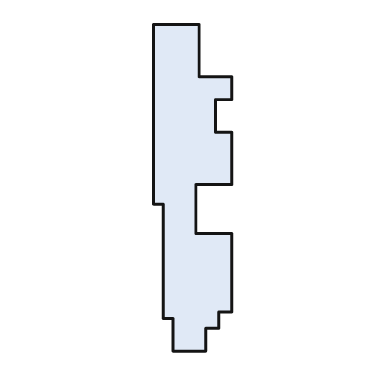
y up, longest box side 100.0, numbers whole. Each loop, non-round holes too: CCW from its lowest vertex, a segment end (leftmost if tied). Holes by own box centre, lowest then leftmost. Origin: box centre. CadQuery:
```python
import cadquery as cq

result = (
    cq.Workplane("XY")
    .moveTo(-6.0, -50.0)
    .lineTo(4.0, -50.0)
    .lineTo(4.0, -43.0)
    .lineTo(8.0, -43.0)
    .lineTo(8.0, -38.0)
    .lineTo(12.0, -38.0)
    .lineTo(12.0, -14.0)
    .lineTo(1.0, -14.0)
    .lineTo(1.0, 1.0)
    .lineTo(12.0, 1.0)
    .lineTo(12.0, 17.0)
    .lineTo(7.0, 17.0)
    .lineTo(7.0, 27.0)
    .lineTo(12.0, 27.0)
    .lineTo(12.0, 34.0)
    .lineTo(2.0, 34.0)
    .lineTo(2.0, 50.0)
    .lineTo(-12.0, 50.0)
    .lineTo(-12.0, -5.0)
    .lineTo(-9.0, -5.0)
    .lineTo(-9.0, -40.0)
    .lineTo(-6.0, -40.0)
    .close()
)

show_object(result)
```